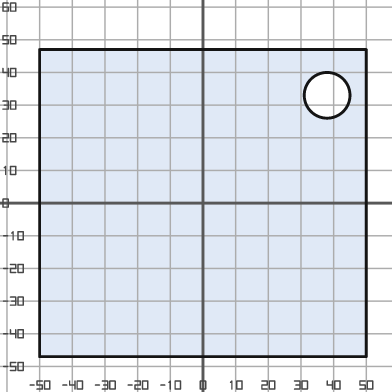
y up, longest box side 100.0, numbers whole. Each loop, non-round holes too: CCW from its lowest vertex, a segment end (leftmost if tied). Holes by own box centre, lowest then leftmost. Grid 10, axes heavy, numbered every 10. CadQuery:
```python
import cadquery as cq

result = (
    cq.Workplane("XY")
    .moveTo(-50.0, -47.0)
    .lineTo(50.0, -47.0)
    .lineTo(50.0, 47.0)
    .lineTo(-50.0, 47.0)
    .close()
    .moveTo(38.0, 33.0)
    .circle(7.0)
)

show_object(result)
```